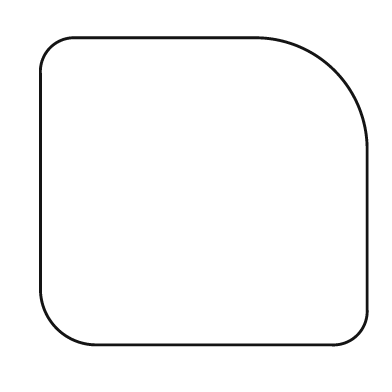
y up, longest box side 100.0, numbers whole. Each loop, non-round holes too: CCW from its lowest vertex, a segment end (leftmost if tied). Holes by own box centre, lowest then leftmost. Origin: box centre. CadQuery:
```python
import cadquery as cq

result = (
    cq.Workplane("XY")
    .moveTo(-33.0, -47.0)
    .lineTo(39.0, -47.0)
    .threePointArc((47.0, -44.0), (50.0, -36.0))
    .lineTo(50.0, 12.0)
    .threePointArc((40.0, 37.0), (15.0, 47.0))
    .lineTo(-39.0, 47.0)
    .threePointArc((-47.0, 44.0), (-50.0, 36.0))
    .lineTo(-50.0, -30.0)
    .threePointArc((-45.0, -42.0), (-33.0, -47.0))
    .close()
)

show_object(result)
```